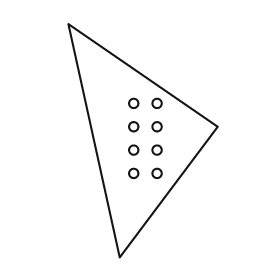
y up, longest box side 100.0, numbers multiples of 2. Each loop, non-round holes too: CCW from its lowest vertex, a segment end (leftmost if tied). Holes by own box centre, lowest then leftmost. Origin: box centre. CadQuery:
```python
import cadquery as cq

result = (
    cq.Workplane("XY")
    .moveTo(-10.0, -50.0)
    .lineTo(32.0, 6.0)
    .lineTo(-32.0, 50.0)
    .close()
    .moveTo(-4.0, -14.0)
    .circle(2.0)
    .moveTo(6.0, -14.0)
    .circle(2.0)
    .moveTo(-4.0, -4.0)
    .circle(2.0)
    .moveTo(6.0, -4.0)
    .circle(2.0)
    .moveTo(-4.0, 6.0)
    .circle(2.0)
    .moveTo(6.0, 6.0)
    .circle(2.0)
    .moveTo(-4.0, 16.0)
    .circle(2.0)
    .moveTo(6.0, 16.0)
    .circle(2.0)
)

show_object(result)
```